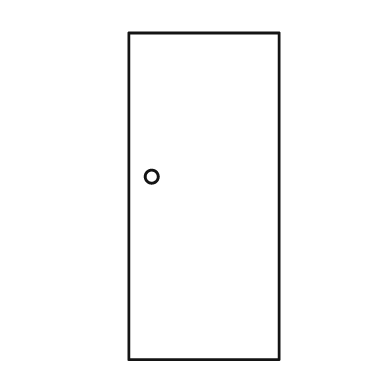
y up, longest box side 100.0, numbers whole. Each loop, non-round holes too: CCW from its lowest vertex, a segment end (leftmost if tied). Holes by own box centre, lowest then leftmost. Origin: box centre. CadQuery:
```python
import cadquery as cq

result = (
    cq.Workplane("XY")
    .moveTo(-23.0, -50.0)
    .lineTo(23.0, -50.0)
    .lineTo(23.0, 50.0)
    .lineTo(-23.0, 50.0)
    .close()
    .moveTo(-16.0, 6.0)
    .circle(2.0)
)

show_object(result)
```